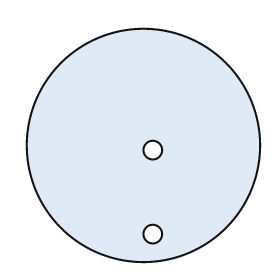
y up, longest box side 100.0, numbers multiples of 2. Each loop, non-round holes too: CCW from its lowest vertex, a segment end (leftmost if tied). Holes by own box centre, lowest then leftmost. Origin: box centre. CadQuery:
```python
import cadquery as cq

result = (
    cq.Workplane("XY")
    .moveTo(0.0, 0.0)
    .circle(50.0)
    .moveTo(4.0, -38.0)
    .circle(4.0)
    .moveTo(4.0, -2.0)
    .circle(4.0)
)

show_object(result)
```